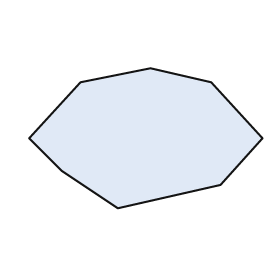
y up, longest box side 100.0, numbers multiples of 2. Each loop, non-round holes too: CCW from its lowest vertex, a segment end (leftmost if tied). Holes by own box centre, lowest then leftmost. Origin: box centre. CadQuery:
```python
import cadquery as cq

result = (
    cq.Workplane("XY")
    .moveTo(-12.0, -30.0)
    .lineTo(32.0, -20.0)
    .lineTo(50.0, 0.0)
    .lineTo(28.0, 24.0)
    .lineTo(2.0, 30.0)
    .lineTo(-28.0, 24.0)
    .lineTo(-50.0, 0.0)
    .lineTo(-36.0, -14.0)
    .close()
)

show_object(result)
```